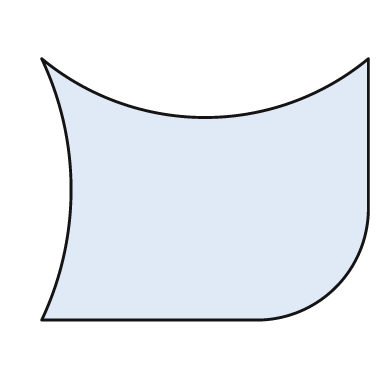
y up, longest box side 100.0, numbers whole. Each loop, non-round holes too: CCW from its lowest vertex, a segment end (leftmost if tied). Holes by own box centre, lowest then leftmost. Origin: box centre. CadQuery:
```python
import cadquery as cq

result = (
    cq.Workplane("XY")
    .moveTo(-50.0, -40.0)
    .lineTo(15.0, -40.0)
    .threePointArc((40.0, -30.0), (50.0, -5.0))
    .lineTo(50.0, 40.0)
    .threePointArc((0.0, 22.0), (-50.0, 40.0))
    .threePointArc((-41.0, 0.0), (-50.0, -40.0))
    .close()
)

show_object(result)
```